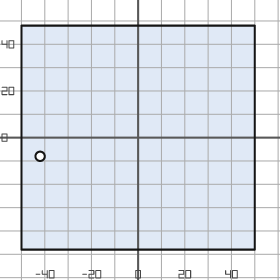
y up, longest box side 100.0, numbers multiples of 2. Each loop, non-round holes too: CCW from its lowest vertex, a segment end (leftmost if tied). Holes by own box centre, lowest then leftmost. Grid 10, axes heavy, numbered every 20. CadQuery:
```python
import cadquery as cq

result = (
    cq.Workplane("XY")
    .moveTo(-50.0, -48.0)
    .lineTo(50.0, -48.0)
    .lineTo(50.0, 48.0)
    .lineTo(-50.0, 48.0)
    .close()
    .moveTo(-42.0, -8.0)
    .circle(2.0)
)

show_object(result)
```